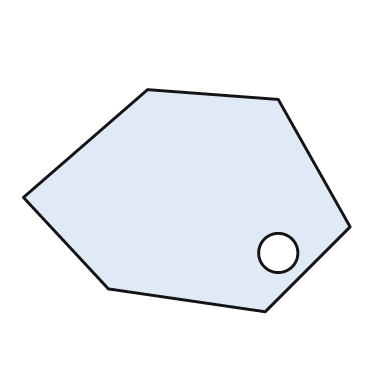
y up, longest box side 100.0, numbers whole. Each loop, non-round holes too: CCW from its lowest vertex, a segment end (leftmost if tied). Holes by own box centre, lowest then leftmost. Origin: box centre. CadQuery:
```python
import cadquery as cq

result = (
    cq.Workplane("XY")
    .moveTo(24.0, -34.0)
    .lineTo(50.0, -8.0)
    .lineTo(28.0, 31.0)
    .lineTo(-12.0, 34.0)
    .lineTo(-50.0, 1.0)
    .lineTo(-24.0, -27.0)
    .close()
    .moveTo(28.0, -16.0)
    .circle(6.0)
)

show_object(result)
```